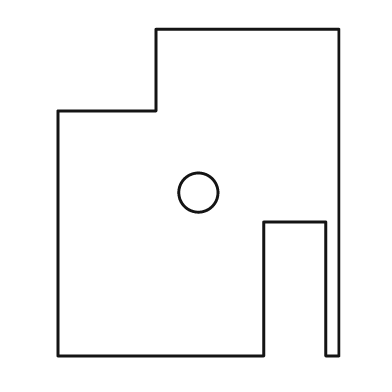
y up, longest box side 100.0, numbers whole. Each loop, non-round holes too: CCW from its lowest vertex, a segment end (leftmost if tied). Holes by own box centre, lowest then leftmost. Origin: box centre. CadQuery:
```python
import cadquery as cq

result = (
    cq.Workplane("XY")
    .moveTo(-43.0, -50.0)
    .lineTo(20.0, -50.0)
    .lineTo(20.0, -9.0)
    .lineTo(39.0, -9.0)
    .lineTo(39.0, -50.0)
    .lineTo(43.0, -50.0)
    .lineTo(43.0, 50.0)
    .lineTo(-13.0, 50.0)
    .lineTo(-13.0, 25.0)
    .lineTo(-43.0, 25.0)
    .close()
    .moveTo(0.0, 0.0)
    .circle(6.0)
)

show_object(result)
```